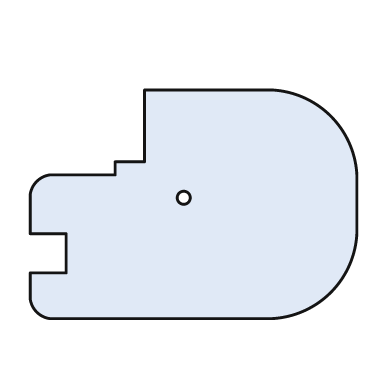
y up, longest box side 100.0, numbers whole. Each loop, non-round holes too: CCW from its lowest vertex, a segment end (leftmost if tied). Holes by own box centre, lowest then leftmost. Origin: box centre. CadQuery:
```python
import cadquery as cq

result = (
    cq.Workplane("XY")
    .moveTo(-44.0, -35.0)
    .lineTo(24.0, -35.0)
    .threePointArc((42.0, -27.0), (50.0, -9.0))
    .lineTo(50.0, 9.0)
    .threePointArc((42.0, 27.0), (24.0, 35.0))
    .lineTo(-15.0, 35.0)
    .lineTo(-15.0, 13.0)
    .lineTo(-24.0, 13.0)
    .lineTo(-24.0, 9.0)
    .lineTo(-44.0, 9.0)
    .threePointArc((-48.0, 7.0), (-50.0, 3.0))
    .lineTo(-50.0, -9.0)
    .lineTo(-39.0, -9.0)
    .lineTo(-39.0, -21.0)
    .lineTo(-50.0, -21.0)
    .lineTo(-50.0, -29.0)
    .threePointArc((-48.0, -33.0), (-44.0, -35.0))
    .close()
    .moveTo(-3.0, 2.0)
    .circle(2.0)
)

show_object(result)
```